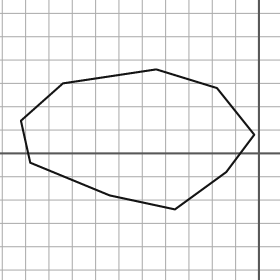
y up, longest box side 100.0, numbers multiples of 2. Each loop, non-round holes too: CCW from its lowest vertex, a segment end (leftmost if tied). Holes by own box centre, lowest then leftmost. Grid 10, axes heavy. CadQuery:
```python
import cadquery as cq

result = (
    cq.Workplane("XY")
    .moveTo(-36.0, -24.0)
    .lineTo(-14.0, -8.0)
    .lineTo(-2.0, 8.0)
    .lineTo(-18.0, 28.0)
    .lineTo(-44.0, 36.0)
    .lineTo(-84.0, 30.0)
    .lineTo(-102.0, 14.0)
    .lineTo(-98.0, -4.0)
    .lineTo(-64.0, -18.0)
    .close()
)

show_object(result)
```